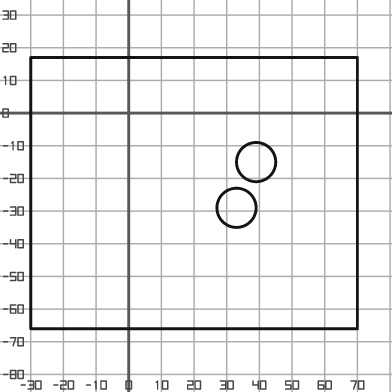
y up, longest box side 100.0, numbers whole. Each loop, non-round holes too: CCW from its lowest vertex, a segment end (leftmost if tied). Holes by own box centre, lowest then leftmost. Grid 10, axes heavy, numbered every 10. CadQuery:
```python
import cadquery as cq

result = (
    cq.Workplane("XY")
    .moveTo(-30.0, -66.0)
    .lineTo(70.0, -66.0)
    .lineTo(70.0, 17.0)
    .lineTo(-30.0, 17.0)
    .close()
    .moveTo(33.0, -29.0)
    .circle(6.0)
    .moveTo(39.0, -15.0)
    .circle(6.0)
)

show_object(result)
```